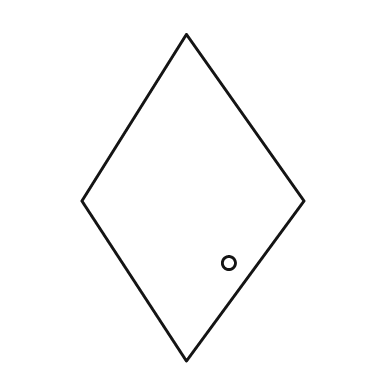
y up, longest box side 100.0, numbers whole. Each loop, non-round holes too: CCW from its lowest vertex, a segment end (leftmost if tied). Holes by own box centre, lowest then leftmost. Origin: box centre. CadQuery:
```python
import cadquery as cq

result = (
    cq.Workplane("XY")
    .moveTo(-2.0, -50.0)
    .lineTo(34.0, -1.0)
    .lineTo(-2.0, 50.0)
    .lineTo(-34.0, -1.0)
    .close()
    .moveTo(11.0, -20.0)
    .circle(2.0)
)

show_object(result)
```